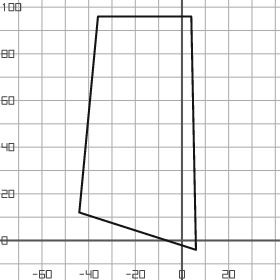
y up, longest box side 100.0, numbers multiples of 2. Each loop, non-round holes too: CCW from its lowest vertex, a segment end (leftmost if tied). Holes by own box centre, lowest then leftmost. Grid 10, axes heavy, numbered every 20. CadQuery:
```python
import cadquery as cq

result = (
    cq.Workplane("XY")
    .moveTo(6.0, -4.0)
    .lineTo(4.0, 96.0)
    .lineTo(-36.0, 96.0)
    .lineTo(-44.0, 12.0)
    .close()
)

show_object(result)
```